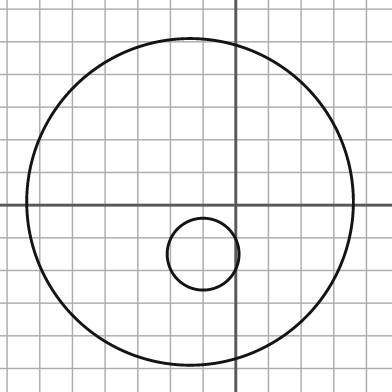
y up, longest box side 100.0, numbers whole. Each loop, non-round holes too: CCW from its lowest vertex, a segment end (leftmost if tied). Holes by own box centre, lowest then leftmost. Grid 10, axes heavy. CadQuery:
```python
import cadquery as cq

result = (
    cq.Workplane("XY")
    .moveTo(-14.0, 1.0)
    .circle(50.0)
    .moveTo(-10.0, -15.0)
    .circle(11.0)
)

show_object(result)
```